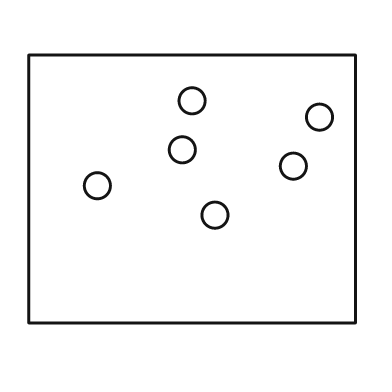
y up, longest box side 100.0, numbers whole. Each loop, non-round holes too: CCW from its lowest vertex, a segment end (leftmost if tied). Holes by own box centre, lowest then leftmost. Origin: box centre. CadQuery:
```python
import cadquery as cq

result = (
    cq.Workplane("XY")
    .moveTo(-50.0, -41.0)
    .lineTo(50.0, -41.0)
    .lineTo(50.0, 41.0)
    .lineTo(-50.0, 41.0)
    .close()
    .moveTo(7.0, -8.0)
    .circle(4.0)
    .moveTo(-29.0, 1.0)
    .circle(4.0)
    .moveTo(31.0, 7.0)
    .circle(4.0)
    .moveTo(-3.0, 12.0)
    .circle(4.0)
    .moveTo(39.0, 22.0)
    .circle(4.0)
    .moveTo(0.0, 27.0)
    .circle(4.0)
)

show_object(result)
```